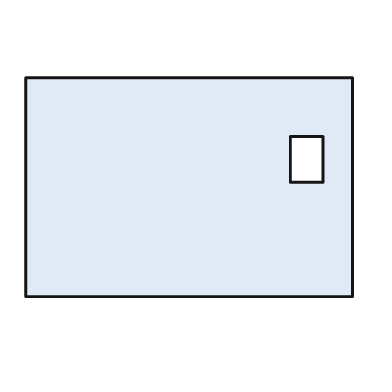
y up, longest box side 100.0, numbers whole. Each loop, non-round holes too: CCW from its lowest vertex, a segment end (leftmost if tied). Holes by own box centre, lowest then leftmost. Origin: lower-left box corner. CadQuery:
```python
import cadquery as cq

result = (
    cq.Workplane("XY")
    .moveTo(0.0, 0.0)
    .lineTo(100.0, 0.0)
    .lineTo(100.0, 67.0)
    .lineTo(0.0, 67.0)
    .close()
    .moveTo(81.0, 35.0)
    .lineTo(91.0, 35.0)
    .lineTo(91.0, 49.0)
    .lineTo(81.0, 49.0)
    .close()
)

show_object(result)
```